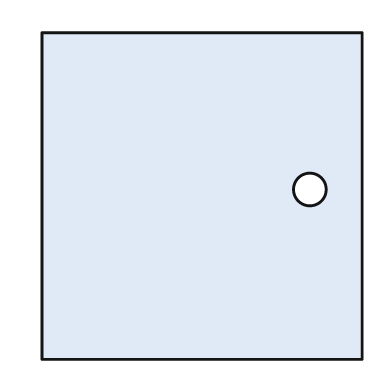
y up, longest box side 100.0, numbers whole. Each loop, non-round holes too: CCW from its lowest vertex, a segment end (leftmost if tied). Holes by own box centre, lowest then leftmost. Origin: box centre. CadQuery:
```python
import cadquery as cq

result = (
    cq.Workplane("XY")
    .moveTo(-49.0, -50.0)
    .lineTo(49.0, -50.0)
    .lineTo(49.0, 50.0)
    .lineTo(-49.0, 50.0)
    .close()
    .moveTo(33.0, 2.0)
    .circle(5.0)
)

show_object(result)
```